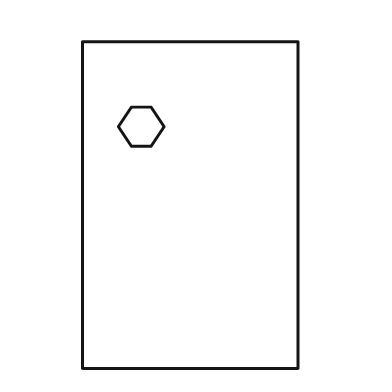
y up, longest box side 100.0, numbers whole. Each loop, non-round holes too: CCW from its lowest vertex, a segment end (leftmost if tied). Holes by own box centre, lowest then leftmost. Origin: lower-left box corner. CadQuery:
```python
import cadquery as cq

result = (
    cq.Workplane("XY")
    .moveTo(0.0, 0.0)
    .lineTo(66.0, 0.0)
    .lineTo(66.0, 100.0)
    .lineTo(0.0, 100.0)
    .close()
    .moveTo(15.0, 68.0)
    .lineTo(21.0, 68.0)
    .lineTo(25.0, 74.0)
    .lineTo(21.0, 80.0)
    .lineTo(15.0, 80.0)
    .lineTo(11.0, 74.0)
    .close()
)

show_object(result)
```